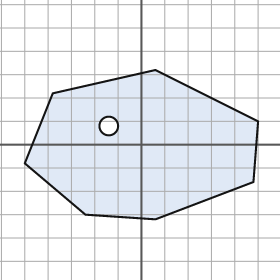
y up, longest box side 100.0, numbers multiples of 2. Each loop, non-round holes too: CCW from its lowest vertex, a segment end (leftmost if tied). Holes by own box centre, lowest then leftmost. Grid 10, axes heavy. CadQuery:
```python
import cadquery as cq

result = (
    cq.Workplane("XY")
    .moveTo(6.0, -32.0)
    .lineTo(48.0, -16.0)
    .lineTo(50.0, 10.0)
    .lineTo(6.0, 32.0)
    .lineTo(-38.0, 22.0)
    .lineTo(-50.0, -8.0)
    .lineTo(-24.0, -30.0)
    .close()
    .moveTo(-14.0, 8.0)
    .circle(4.0)
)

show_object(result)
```